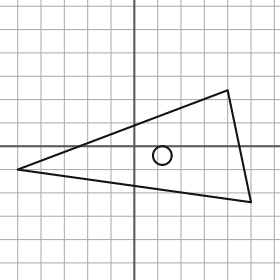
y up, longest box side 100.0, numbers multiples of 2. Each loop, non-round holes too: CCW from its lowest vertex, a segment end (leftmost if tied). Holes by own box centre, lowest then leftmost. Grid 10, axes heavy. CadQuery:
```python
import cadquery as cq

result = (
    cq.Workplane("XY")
    .moveTo(50.0, -24.0)
    .lineTo(40.0, 24.0)
    .lineTo(-50.0, -10.0)
    .close()
    .moveTo(12.0, -4.0)
    .circle(4.0)
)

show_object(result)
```